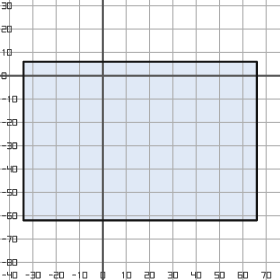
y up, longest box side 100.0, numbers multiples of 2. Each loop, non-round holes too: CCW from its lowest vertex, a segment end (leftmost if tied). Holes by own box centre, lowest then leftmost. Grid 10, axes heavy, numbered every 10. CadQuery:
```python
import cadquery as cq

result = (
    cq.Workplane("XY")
    .moveTo(-34.0, -62.0)
    .lineTo(66.0, -62.0)
    .lineTo(66.0, 6.0)
    .lineTo(-34.0, 6.0)
    .close()
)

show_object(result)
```